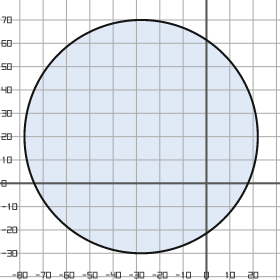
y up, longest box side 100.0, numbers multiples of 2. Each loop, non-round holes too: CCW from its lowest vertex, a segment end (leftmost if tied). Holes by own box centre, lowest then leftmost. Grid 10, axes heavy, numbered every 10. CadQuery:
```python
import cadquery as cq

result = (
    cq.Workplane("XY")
    .moveTo(-28.0, 20.0)
    .circle(50.0)
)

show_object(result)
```